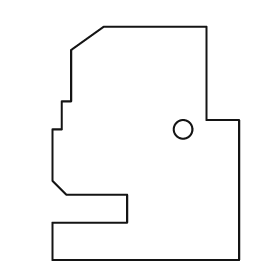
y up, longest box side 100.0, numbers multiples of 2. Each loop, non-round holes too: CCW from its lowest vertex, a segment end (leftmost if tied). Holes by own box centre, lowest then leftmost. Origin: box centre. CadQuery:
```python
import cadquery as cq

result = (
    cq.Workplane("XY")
    .moveTo(-40.0, -50.0)
    .lineTo(40.0, -50.0)
    .lineTo(40.0, 10.0)
    .lineTo(26.0, 10.0)
    .lineTo(26.0, 50.0)
    .lineTo(-18.0, 50.0)
    .lineTo(-32.0, 40.0)
    .lineTo(-32.0, 18.0)
    .lineTo(-36.0, 18.0)
    .lineTo(-36.0, 6.0)
    .lineTo(-40.0, 6.0)
    .lineTo(-40.0, -16.0)
    .lineTo(-34.0, -22.0)
    .lineTo(-8.0, -22.0)
    .lineTo(-8.0, -34.0)
    .lineTo(-40.0, -34.0)
    .close()
    .moveTo(16.0, 6.0)
    .circle(4.0)
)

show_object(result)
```